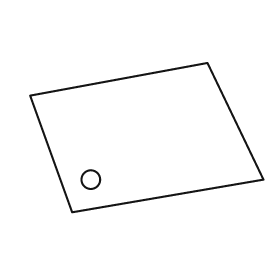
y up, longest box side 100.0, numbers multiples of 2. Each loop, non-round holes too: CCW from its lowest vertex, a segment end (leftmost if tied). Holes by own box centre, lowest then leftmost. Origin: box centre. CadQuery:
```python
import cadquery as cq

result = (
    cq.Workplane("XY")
    .moveTo(-32.0, -32.0)
    .lineTo(50.0, -18.0)
    .lineTo(26.0, 32.0)
    .lineTo(-50.0, 18.0)
    .close()
    .moveTo(-24.0, -18.0)
    .circle(4.0)
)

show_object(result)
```